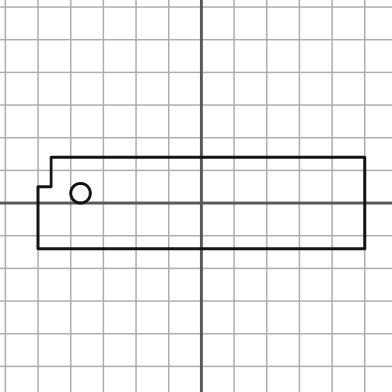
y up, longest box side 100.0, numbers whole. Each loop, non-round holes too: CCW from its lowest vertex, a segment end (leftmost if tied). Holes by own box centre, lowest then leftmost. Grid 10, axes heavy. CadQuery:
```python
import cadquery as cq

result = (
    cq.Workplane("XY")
    .moveTo(-50.0, -14.0)
    .lineTo(50.0, -14.0)
    .lineTo(50.0, 14.0)
    .lineTo(-46.0, 14.0)
    .lineTo(-46.0, 5.0)
    .lineTo(-50.0, 5.0)
    .close()
    .moveTo(-37.0, 3.0)
    .circle(3.0)
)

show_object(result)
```